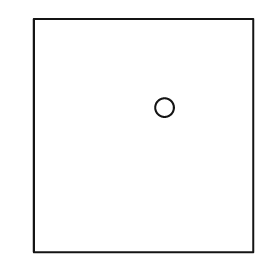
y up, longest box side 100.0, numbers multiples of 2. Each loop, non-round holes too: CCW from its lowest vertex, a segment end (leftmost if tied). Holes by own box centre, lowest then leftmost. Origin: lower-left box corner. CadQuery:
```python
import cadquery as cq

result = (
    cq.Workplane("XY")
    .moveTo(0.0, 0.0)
    .lineTo(94.0, 0.0)
    .lineTo(94.0, 100.0)
    .lineTo(0.0, 100.0)
    .close()
    .moveTo(56.0, 62.0)
    .circle(4.0)
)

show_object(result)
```